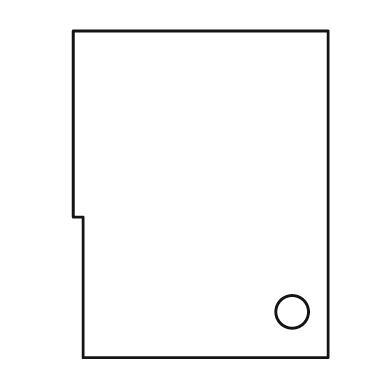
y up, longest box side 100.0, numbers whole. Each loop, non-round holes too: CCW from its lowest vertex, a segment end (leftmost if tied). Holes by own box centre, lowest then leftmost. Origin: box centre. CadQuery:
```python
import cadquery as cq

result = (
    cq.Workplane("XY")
    .moveTo(-36.0, -50.0)
    .lineTo(39.0, -50.0)
    .lineTo(39.0, 50.0)
    .lineTo(-39.0, 50.0)
    .lineTo(-39.0, -7.0)
    .lineTo(-36.0, -7.0)
    .close()
    .moveTo(28.0, -36.0)
    .circle(5.0)
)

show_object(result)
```